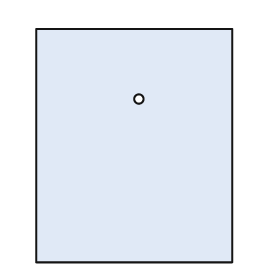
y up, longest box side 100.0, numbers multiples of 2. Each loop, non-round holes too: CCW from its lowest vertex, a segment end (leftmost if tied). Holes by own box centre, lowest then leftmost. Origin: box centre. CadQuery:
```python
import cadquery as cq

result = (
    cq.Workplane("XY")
    .moveTo(-42.0, -50.0)
    .lineTo(42.0, -50.0)
    .lineTo(42.0, 50.0)
    .lineTo(-42.0, 50.0)
    .close()
    .moveTo(2.0, 20.0)
    .circle(2.0)
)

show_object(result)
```